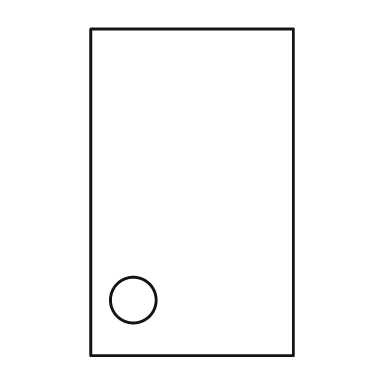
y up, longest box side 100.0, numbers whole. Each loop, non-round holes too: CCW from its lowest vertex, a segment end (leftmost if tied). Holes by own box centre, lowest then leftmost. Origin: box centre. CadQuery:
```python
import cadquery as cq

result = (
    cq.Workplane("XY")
    .moveTo(-31.0, -50.0)
    .lineTo(31.0, -50.0)
    .lineTo(31.0, 50.0)
    .lineTo(-31.0, 50.0)
    .close()
    .moveTo(-18.0, -33.0)
    .circle(7.0)
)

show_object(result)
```